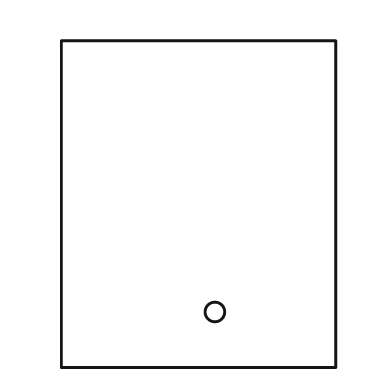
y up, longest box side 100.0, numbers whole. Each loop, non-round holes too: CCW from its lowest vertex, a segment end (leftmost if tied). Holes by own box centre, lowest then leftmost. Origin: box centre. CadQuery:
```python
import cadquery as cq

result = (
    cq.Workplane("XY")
    .moveTo(-42.0, -50.0)
    .lineTo(42.0, -50.0)
    .lineTo(42.0, 50.0)
    .lineTo(-42.0, 50.0)
    .close()
    .moveTo(5.0, -33.0)
    .circle(3.0)
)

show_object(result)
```